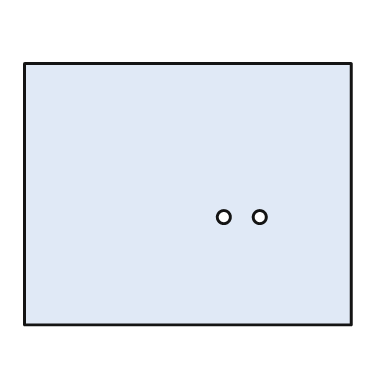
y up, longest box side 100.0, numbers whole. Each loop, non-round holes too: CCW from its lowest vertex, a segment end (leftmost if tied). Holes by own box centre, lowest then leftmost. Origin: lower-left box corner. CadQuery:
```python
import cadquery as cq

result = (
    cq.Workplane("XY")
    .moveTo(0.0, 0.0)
    .lineTo(100.0, 0.0)
    .lineTo(100.0, 80.0)
    .lineTo(0.0, 80.0)
    .close()
    .moveTo(61.0, 33.0)
    .circle(2.0)
    .moveTo(72.0, 33.0)
    .circle(2.0)
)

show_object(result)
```